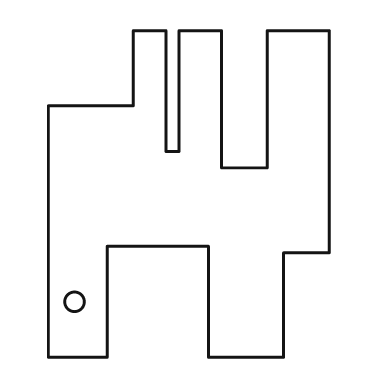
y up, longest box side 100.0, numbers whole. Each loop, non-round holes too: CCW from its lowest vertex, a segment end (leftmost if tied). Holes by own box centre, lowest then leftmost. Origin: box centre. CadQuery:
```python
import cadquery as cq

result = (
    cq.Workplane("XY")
    .moveTo(-43.0, -50.0)
    .lineTo(-25.0, -50.0)
    .lineTo(-25.0, -16.0)
    .lineTo(6.0, -16.0)
    .lineTo(6.0, -50.0)
    .lineTo(29.0, -50.0)
    .lineTo(29.0, -18.0)
    .lineTo(43.0, -18.0)
    .lineTo(43.0, 50.0)
    .lineTo(24.0, 50.0)
    .lineTo(24.0, 8.0)
    .lineTo(10.0, 8.0)
    .lineTo(10.0, 50.0)
    .lineTo(-3.0, 50.0)
    .lineTo(-3.0, 13.0)
    .lineTo(-7.0, 13.0)
    .lineTo(-7.0, 50.0)
    .lineTo(-17.0, 50.0)
    .lineTo(-17.0, 27.0)
    .lineTo(-43.0, 27.0)
    .close()
    .moveTo(-35.0, -33.0)
    .circle(3.0)
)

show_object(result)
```